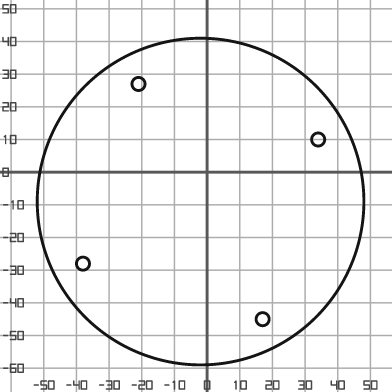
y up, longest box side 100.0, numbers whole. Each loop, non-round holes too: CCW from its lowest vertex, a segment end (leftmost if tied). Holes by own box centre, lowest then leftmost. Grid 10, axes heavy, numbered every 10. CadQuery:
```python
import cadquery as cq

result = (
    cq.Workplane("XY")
    .moveTo(-2.0, -9.0)
    .circle(50.0)
    .moveTo(17.0, -45.0)
    .circle(2.0)
    .moveTo(-38.0, -28.0)
    .circle(2.0)
    .moveTo(34.0, 10.0)
    .circle(2.0)
    .moveTo(-21.0, 27.0)
    .circle(2.0)
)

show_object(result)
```